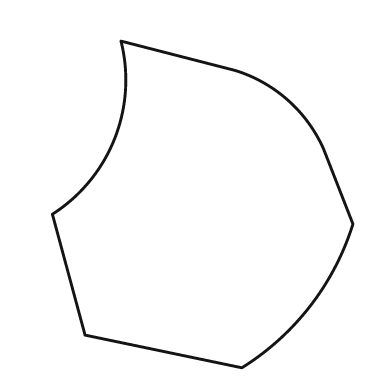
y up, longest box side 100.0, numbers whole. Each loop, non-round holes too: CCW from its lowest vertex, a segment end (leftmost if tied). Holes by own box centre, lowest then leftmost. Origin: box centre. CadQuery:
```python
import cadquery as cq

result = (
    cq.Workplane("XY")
    .moveTo(12.0, -50.0)
    .threePointArc((33.0, -31.0), (46.0, -6.0))
    .lineTo(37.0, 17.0)
    .threePointArc((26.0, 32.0), (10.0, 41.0))
    .lineTo(-25.0, 50.0)
    .threePointArc((-27.0, 20.0), (-46.0, -3.0))
    .lineTo(-36.0, -40.0)
    .close()
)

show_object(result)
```